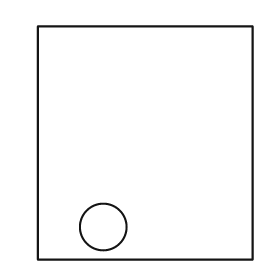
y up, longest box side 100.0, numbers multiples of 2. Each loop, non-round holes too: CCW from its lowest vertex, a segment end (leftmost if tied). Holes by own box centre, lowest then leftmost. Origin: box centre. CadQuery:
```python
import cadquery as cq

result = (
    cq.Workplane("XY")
    .moveTo(-46.0, -50.0)
    .lineTo(46.0, -50.0)
    .lineTo(46.0, 50.0)
    .lineTo(-46.0, 50.0)
    .close()
    .moveTo(-18.0, -36.0)
    .circle(10.0)
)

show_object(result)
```